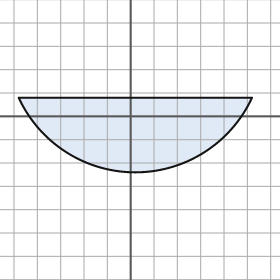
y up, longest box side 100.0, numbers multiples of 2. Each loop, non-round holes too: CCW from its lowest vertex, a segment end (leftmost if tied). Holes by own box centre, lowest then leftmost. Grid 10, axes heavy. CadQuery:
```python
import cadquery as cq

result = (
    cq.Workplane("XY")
    .moveTo(-48.0, 8.0)
    .threePointArc((2.0, -24.0), (52.0, 8.0))
    .close()
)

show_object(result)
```